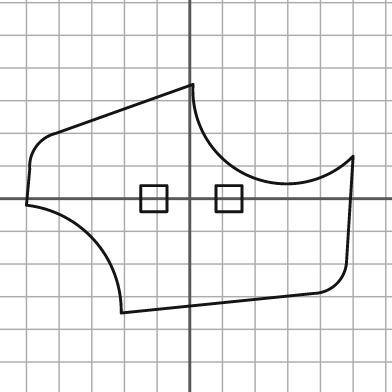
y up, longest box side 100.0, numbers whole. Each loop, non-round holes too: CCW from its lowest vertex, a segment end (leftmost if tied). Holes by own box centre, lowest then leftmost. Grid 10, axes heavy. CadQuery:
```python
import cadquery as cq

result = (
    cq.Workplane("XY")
    .moveTo(-21.0, -35.0)
    .lineTo(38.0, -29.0)
    .threePointArc((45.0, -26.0), (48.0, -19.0))
    .lineTo(50.0, 13.0)
    .threePointArc((18.0, 7.0), (1.0, 35.0))
    .lineTo(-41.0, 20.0)
    .threePointArc((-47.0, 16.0), (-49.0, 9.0))
    .lineTo(-50.0, -2.0)
    .threePointArc((-29.0, -13.0), (-21.0, -35.0))
    .close()
    .moveTo(-15.0, -4.0)
    .lineTo(-7.0, -4.0)
    .lineTo(-7.0, 4.0)
    .lineTo(-15.0, 4.0)
    .close()
    .moveTo(8.0, -4.0)
    .lineTo(16.0, -4.0)
    .lineTo(16.0, 4.0)
    .lineTo(8.0, 4.0)
    .close()
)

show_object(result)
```